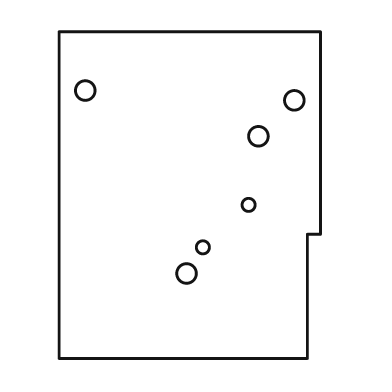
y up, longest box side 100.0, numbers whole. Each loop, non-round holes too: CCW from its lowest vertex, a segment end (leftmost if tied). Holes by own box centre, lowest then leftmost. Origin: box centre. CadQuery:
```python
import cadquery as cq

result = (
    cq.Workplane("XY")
    .moveTo(-40.0, -50.0)
    .lineTo(36.0, -50.0)
    .lineTo(36.0, -12.0)
    .lineTo(40.0, -12.0)
    .lineTo(40.0, 50.0)
    .lineTo(-40.0, 50.0)
    .close()
    .moveTo(-1.0, -24.0)
    .circle(3.0)
    .moveTo(4.0, -16.0)
    .circle(2.0)
    .moveTo(18.0, -3.0)
    .circle(2.0)
    .moveTo(21.0, 18.0)
    .circle(3.0)
    .moveTo(32.0, 29.0)
    .circle(3.0)
    .moveTo(-32.0, 32.0)
    .circle(3.0)
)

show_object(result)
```